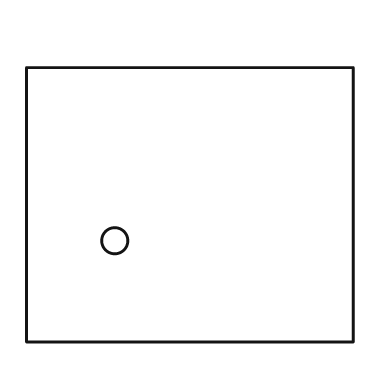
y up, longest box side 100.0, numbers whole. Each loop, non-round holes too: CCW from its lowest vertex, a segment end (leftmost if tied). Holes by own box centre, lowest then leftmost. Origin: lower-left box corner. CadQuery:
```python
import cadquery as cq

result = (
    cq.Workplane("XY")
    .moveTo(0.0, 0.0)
    .lineTo(100.0, 0.0)
    .lineTo(100.0, 84.0)
    .lineTo(0.0, 84.0)
    .close()
    .moveTo(27.0, 31.0)
    .circle(4.0)
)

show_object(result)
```